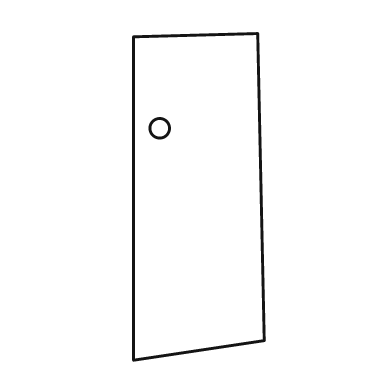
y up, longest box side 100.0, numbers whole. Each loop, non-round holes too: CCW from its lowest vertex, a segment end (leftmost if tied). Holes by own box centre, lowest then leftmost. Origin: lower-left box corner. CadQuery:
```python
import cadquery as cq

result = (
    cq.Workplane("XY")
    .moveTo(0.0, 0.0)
    .lineTo(40.0, 6.0)
    .lineTo(38.0, 100.0)
    .lineTo(0.0, 99.0)
    .close()
    .moveTo(8.0, 71.0)
    .circle(3.0)
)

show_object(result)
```